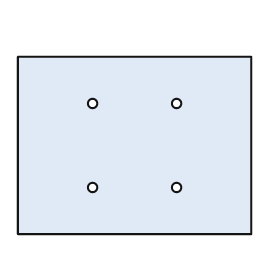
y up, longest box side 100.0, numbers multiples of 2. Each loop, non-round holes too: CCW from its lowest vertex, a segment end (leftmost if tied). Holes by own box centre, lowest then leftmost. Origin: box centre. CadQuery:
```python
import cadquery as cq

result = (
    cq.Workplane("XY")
    .moveTo(-50.0, -38.0)
    .lineTo(50.0, -38.0)
    .lineTo(50.0, 38.0)
    .lineTo(-50.0, 38.0)
    .close()
    .moveTo(-18.0, -18.0)
    .circle(2.0)
    .moveTo(18.0, -18.0)
    .circle(2.0)
    .moveTo(-18.0, 18.0)
    .circle(2.0)
    .moveTo(18.0, 18.0)
    .circle(2.0)
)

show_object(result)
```